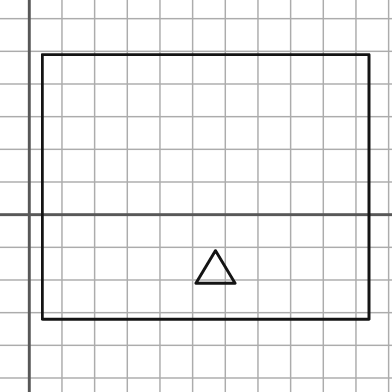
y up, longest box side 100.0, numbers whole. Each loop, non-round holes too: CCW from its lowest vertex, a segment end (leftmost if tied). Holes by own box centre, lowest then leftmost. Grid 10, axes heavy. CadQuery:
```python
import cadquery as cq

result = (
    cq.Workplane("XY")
    .moveTo(4.0, -32.0)
    .lineTo(104.0, -32.0)
    .lineTo(104.0, 49.0)
    .lineTo(4.0, 49.0)
    .close()
    .moveTo(51.0, -21.0)
    .lineTo(63.0, -21.0)
    .lineTo(57.0, -11.0)
    .close()
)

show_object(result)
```